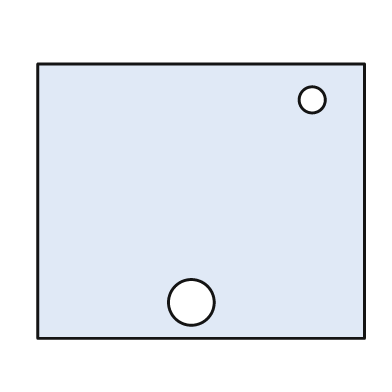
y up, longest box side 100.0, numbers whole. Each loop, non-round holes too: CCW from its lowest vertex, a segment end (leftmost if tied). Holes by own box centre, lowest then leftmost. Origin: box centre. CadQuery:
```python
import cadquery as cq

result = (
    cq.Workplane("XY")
    .moveTo(-50.0, -42.0)
    .lineTo(50.0, -42.0)
    .lineTo(50.0, 42.0)
    .lineTo(-50.0, 42.0)
    .close()
    .moveTo(-3.0, -31.0)
    .circle(7.0)
    .moveTo(34.0, 31.0)
    .circle(4.0)
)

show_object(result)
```